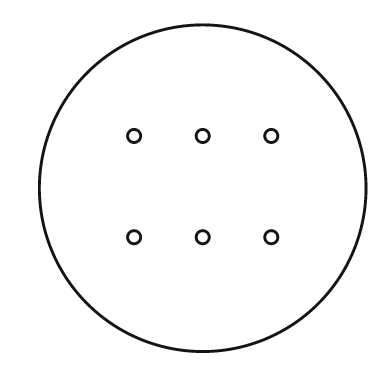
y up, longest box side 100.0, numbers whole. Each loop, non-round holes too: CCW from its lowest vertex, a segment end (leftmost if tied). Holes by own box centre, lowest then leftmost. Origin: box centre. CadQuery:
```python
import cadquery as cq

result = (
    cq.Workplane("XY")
    .moveTo(0.0, 0.0)
    .circle(50.0)
    .moveTo(-21.0, -15.0)
    .circle(2.0)
    .moveTo(0.0, -15.0)
    .circle(2.0)
    .moveTo(21.0, -15.0)
    .circle(2.0)
    .moveTo(-21.0, 16.0)
    .circle(2.0)
    .moveTo(0.0, 16.0)
    .circle(2.0)
    .moveTo(21.0, 16.0)
    .circle(2.0)
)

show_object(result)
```